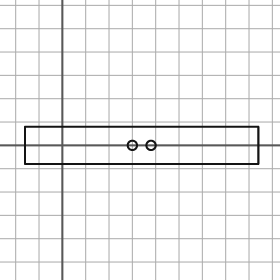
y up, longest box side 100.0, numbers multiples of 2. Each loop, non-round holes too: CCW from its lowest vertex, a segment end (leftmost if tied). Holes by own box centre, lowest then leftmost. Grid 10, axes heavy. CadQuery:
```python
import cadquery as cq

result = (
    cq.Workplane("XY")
    .moveTo(-16.0, -8.0)
    .lineTo(84.0, -8.0)
    .lineTo(84.0, 8.0)
    .lineTo(-16.0, 8.0)
    .close()
    .moveTo(30.0, 0.0)
    .circle(2.0)
    .moveTo(38.0, 0.0)
    .circle(2.0)
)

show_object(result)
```